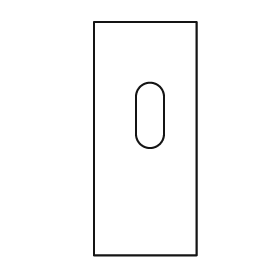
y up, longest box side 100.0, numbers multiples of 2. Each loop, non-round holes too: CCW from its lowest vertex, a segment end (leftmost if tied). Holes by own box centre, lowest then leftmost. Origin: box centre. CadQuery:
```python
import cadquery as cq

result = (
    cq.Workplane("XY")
    .moveTo(-22.0, -50.0)
    .lineTo(22.0, -50.0)
    .lineTo(22.0, 50.0)
    .lineTo(-22.0, 50.0)
    .close()
    .moveTo(-4.0, 2.0)
    .threePointArc((2.0, -4.0), (8.0, 2.0))
    .lineTo(8.0, 18.0)
    .threePointArc((2.0, 24.0), (-4.0, 18.0))
    .close()
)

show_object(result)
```